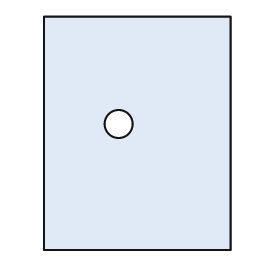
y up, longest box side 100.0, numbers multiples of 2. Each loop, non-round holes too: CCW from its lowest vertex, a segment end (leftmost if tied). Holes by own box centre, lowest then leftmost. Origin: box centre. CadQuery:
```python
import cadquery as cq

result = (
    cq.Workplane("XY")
    .moveTo(-40.0, -50.0)
    .lineTo(40.0, -50.0)
    .lineTo(40.0, 50.0)
    .lineTo(-40.0, 50.0)
    .close()
    .moveTo(-8.0, 4.0)
    .circle(6.0)
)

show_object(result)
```